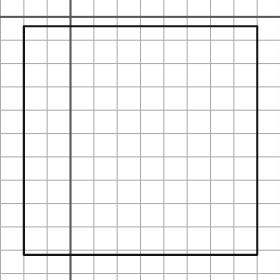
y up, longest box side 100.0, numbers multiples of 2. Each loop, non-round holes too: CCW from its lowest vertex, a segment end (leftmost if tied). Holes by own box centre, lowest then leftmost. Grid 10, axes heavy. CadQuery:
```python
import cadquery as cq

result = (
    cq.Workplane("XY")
    .moveTo(-20.0, -102.0)
    .lineTo(80.0, -102.0)
    .lineTo(80.0, -4.0)
    .lineTo(-20.0, -4.0)
    .close()
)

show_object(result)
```